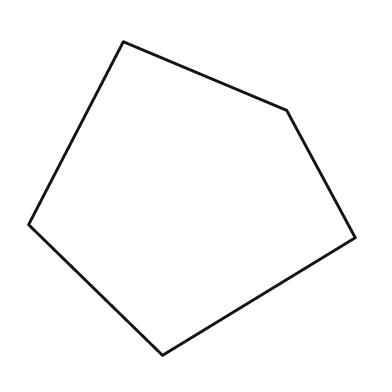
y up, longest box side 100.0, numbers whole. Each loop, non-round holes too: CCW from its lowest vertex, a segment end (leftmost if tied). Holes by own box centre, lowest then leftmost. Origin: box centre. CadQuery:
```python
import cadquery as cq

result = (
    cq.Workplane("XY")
    .moveTo(-9.0, -48.0)
    .lineTo(50.0, -12.0)
    .lineTo(29.0, 27.0)
    .lineTo(-21.0, 48.0)
    .lineTo(-50.0, -8.0)
    .close()
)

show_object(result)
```